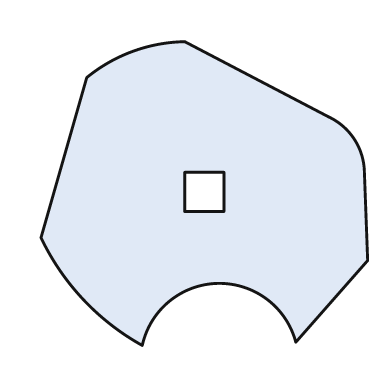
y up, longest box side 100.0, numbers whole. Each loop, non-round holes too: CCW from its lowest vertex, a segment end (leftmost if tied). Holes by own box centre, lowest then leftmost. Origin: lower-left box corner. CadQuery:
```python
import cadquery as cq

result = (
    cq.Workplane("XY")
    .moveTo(31.0, 0.0)
    .threePointArc((54.0, 19.0), (78.0, 1.0))
    .lineTo(100.0, 26.0)
    .lineTo(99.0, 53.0)
    .threePointArc((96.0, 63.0), (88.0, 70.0))
    .lineTo(44.0, 93.0)
    .threePointArc((28.0, 90.0), (14.0, 82.0))
    .lineTo(0.0, 33.0)
    .threePointArc((13.0, 14.0), (31.0, 0.0))
    .close()
    .moveTo(44.0, 41.0)
    .lineTo(56.0, 41.0)
    .lineTo(56.0, 53.0)
    .lineTo(44.0, 53.0)
    .close()
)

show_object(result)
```